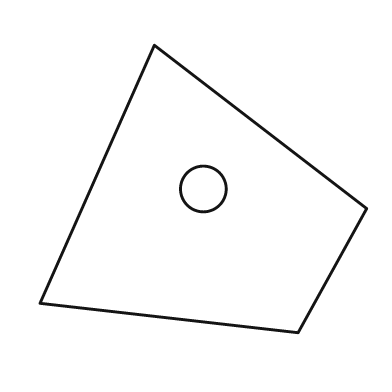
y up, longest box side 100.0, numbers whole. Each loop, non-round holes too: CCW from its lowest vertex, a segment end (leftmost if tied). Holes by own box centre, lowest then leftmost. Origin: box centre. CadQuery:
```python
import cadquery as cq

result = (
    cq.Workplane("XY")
    .moveTo(29.0, -44.0)
    .lineTo(50.0, -6.0)
    .lineTo(-15.0, 44.0)
    .lineTo(-50.0, -35.0)
    .close()
    .moveTo(0.0, 0.0)
    .circle(7.0)
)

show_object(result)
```